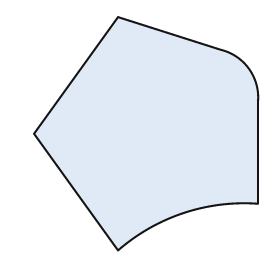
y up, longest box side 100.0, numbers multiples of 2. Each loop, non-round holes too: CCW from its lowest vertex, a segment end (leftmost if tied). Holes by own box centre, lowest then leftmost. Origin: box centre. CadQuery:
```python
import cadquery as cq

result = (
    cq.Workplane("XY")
    .moveTo(-12.0, -50.0)
    .threePointArc((16.0, -34.0), (48.0, -30.0))
    .lineTo(48.0, 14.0)
    .threePointArc((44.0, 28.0), (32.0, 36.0))
    .lineTo(-12.0, 50.0)
    .lineTo(-48.0, 0.0)
    .close()
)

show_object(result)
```